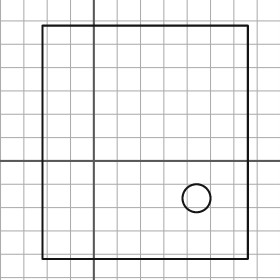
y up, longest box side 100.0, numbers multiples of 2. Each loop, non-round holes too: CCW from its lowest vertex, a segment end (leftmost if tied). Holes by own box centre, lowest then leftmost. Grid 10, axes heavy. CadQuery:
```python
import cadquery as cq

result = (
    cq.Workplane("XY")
    .moveTo(-22.0, -42.0)
    .lineTo(66.0, -42.0)
    .lineTo(66.0, 58.0)
    .lineTo(-22.0, 58.0)
    .close()
    .moveTo(44.0, -16.0)
    .circle(6.0)
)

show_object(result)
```